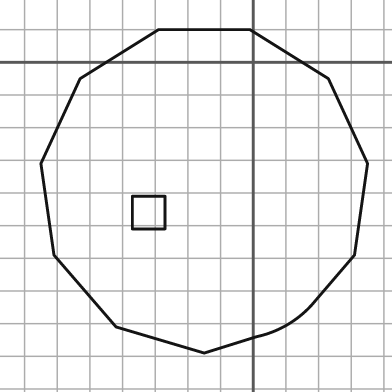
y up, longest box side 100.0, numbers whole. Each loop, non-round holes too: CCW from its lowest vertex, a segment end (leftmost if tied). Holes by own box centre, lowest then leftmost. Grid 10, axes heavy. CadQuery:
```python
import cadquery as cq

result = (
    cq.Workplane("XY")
    .moveTo(-15.0, -89.0)
    .lineTo(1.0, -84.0)
    .threePointArc((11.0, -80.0), (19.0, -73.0))
    .lineTo(31.0, -59.0)
    .lineTo(35.0, -31.0)
    .lineTo(23.0, -5.0)
    .lineTo(-1.0, 10.0)
    .lineTo(-29.0, 10.0)
    .lineTo(-53.0, -5.0)
    .lineTo(-65.0, -31.0)
    .lineTo(-61.0, -59.0)
    .lineTo(-42.0, -81.0)
    .close()
    .moveTo(-37.0, -51.0)
    .lineTo(-27.0, -51.0)
    .lineTo(-27.0, -41.0)
    .lineTo(-37.0, -41.0)
    .close()
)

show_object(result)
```